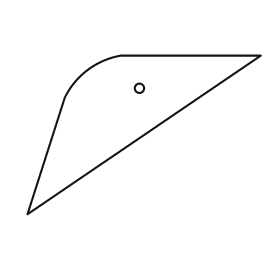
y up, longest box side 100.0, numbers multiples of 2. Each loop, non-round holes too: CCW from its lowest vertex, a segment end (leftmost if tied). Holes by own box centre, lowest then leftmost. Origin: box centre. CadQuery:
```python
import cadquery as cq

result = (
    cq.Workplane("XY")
    .moveTo(-50.0, -34.0)
    .lineTo(50.0, 34.0)
    .lineTo(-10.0, 34.0)
    .threePointArc((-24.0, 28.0), (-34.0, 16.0))
    .close()
    .moveTo(-2.0, 20.0)
    .circle(2.0)
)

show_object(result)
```